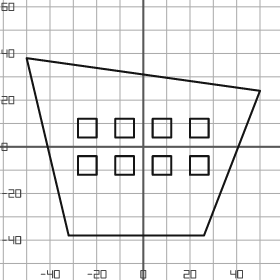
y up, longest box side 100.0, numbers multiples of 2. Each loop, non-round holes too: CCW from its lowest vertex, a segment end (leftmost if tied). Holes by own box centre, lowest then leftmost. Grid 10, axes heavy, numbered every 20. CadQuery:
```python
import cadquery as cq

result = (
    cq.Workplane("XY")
    .moveTo(-32.0, -38.0)
    .lineTo(26.0, -38.0)
    .lineTo(50.0, 24.0)
    .lineTo(-50.0, 38.0)
    .close()
    .moveTo(-28.0, -12.0)
    .lineTo(-20.0, -12.0)
    .lineTo(-20.0, -4.0)
    .lineTo(-28.0, -4.0)
    .close()
    .moveTo(-12.0, -12.0)
    .lineTo(-4.0, -12.0)
    .lineTo(-4.0, -4.0)
    .lineTo(-12.0, -4.0)
    .close()
    .moveTo(4.0, -12.0)
    .lineTo(12.0, -12.0)
    .lineTo(12.0, -4.0)
    .lineTo(4.0, -4.0)
    .close()
    .moveTo(20.0, -12.0)
    .lineTo(28.0, -12.0)
    .lineTo(28.0, -4.0)
    .lineTo(20.0, -4.0)
    .close()
    .moveTo(-28.0, 4.0)
    .lineTo(-20.0, 4.0)
    .lineTo(-20.0, 12.0)
    .lineTo(-28.0, 12.0)
    .close()
    .moveTo(-12.0, 4.0)
    .lineTo(-4.0, 4.0)
    .lineTo(-4.0, 12.0)
    .lineTo(-12.0, 12.0)
    .close()
    .moveTo(4.0, 4.0)
    .lineTo(12.0, 4.0)
    .lineTo(12.0, 12.0)
    .lineTo(4.0, 12.0)
    .close()
    .moveTo(20.0, 4.0)
    .lineTo(28.0, 4.0)
    .lineTo(28.0, 12.0)
    .lineTo(20.0, 12.0)
    .close()
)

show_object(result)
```